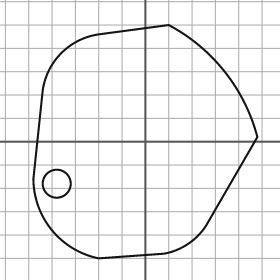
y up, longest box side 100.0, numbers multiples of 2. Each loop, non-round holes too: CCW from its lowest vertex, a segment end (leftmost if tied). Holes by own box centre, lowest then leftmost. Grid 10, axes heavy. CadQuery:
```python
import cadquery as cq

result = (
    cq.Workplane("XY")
    .moveTo(-20.0, -50.0)
    .lineTo(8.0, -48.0)
    .threePointArc((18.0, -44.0), (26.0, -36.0))
    .lineTo(48.0, 2.0)
    .threePointArc((34.0, 30.0), (10.0, 50.0))
    .lineTo(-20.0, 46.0)
    .threePointArc((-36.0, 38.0), (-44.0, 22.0))
    .lineTo(-48.0, -16.0)
    .threePointArc((-40.0, -38.0), (-20.0, -50.0))
    .close()
    .moveTo(-38.0, -18.0)
    .circle(6.0)
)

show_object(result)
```